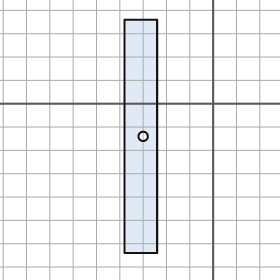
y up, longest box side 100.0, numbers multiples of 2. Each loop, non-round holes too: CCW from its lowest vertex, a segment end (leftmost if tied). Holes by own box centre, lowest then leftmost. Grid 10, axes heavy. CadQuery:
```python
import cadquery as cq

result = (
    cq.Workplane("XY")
    .moveTo(-38.0, -64.0)
    .lineTo(-24.0, -64.0)
    .lineTo(-24.0, 36.0)
    .lineTo(-38.0, 36.0)
    .close()
    .moveTo(-30.0, -14.0)
    .circle(2.0)
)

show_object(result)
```